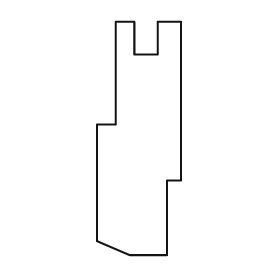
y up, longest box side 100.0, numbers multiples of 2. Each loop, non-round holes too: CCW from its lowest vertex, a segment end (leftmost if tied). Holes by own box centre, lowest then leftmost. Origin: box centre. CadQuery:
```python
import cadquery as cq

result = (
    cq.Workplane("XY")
    .moveTo(-4.0, -50.0)
    .lineTo(12.0, -50.0)
    .lineTo(12.0, -18.0)
    .lineTo(18.0, -18.0)
    .lineTo(18.0, 50.0)
    .lineTo(8.0, 50.0)
    .lineTo(8.0, 36.0)
    .lineTo(-2.0, 36.0)
    .lineTo(-2.0, 50.0)
    .lineTo(-10.0, 50.0)
    .lineTo(-10.0, 6.0)
    .lineTo(-18.0, 6.0)
    .lineTo(-18.0, -44.0)
    .close()
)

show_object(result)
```